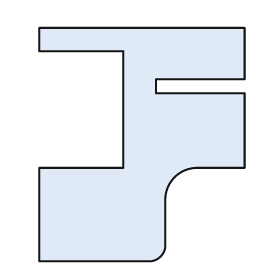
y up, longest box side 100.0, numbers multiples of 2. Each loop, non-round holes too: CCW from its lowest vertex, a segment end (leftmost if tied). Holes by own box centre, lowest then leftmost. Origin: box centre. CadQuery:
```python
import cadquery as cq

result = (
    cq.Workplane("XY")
    .moveTo(-44.0, -50.0)
    .lineTo(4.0, -50.0)
    .threePointArc((8.0, -48.0), (10.0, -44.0))
    .lineTo(10.0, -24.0)
    .threePointArc((14.0, -14.0), (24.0, -10.0))
    .lineTo(44.0, -10.0)
    .lineTo(44.0, 22.0)
    .lineTo(6.0, 22.0)
    .lineTo(6.0, 28.0)
    .lineTo(44.0, 28.0)
    .lineTo(44.0, 50.0)
    .lineTo(-44.0, 50.0)
    .lineTo(-44.0, 40.0)
    .lineTo(-8.0, 40.0)
    .lineTo(-8.0, -10.0)
    .lineTo(-44.0, -10.0)
    .close()
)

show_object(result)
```